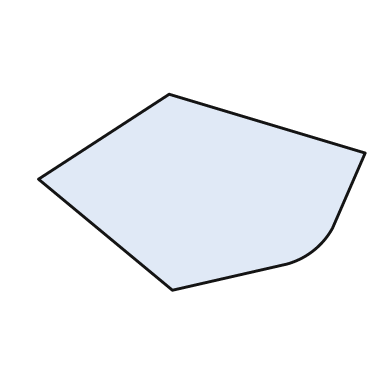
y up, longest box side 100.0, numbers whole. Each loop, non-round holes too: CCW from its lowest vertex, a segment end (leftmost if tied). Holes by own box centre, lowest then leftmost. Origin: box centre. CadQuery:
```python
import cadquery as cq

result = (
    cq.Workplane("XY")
    .moveTo(-9.0, -30.0)
    .lineTo(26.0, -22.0)
    .threePointArc((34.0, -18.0), (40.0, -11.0))
    .lineTo(50.0, 12.0)
    .lineTo(-10.0, 30.0)
    .lineTo(-50.0, 4.0)
    .close()
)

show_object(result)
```